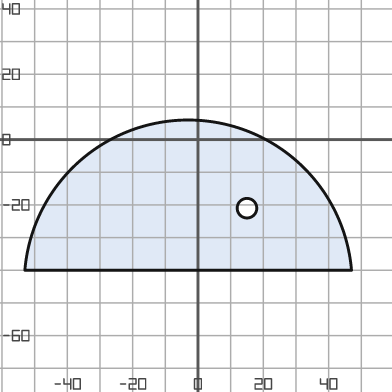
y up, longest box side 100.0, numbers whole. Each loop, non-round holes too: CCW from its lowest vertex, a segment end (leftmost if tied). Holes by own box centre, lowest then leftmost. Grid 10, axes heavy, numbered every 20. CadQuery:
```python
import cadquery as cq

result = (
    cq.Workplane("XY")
    .moveTo(-53.0, -40.0)
    .lineTo(47.0, -40.0)
    .threePointArc((-3.0, 6.0), (-53.0, -40.0))
    .close()
    .moveTo(15.0, -21.0)
    .circle(3.0)
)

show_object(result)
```